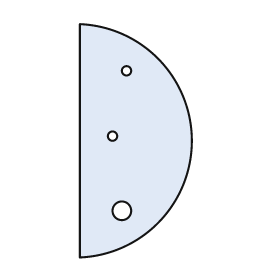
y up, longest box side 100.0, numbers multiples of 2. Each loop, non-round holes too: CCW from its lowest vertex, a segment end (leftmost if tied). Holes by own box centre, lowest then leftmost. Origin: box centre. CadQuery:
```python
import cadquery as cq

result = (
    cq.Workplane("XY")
    .moveTo(-24.0, -50.0)
    .threePointArc((24.0, 0.0), (-24.0, 50.0))
    .close()
    .moveTo(-6.0, -30.0)
    .circle(4.0)
    .moveTo(-10.0, 2.0)
    .circle(2.0)
    .moveTo(-4.0, 30.0)
    .circle(2.0)
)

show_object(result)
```